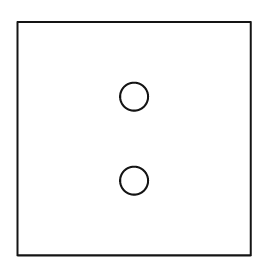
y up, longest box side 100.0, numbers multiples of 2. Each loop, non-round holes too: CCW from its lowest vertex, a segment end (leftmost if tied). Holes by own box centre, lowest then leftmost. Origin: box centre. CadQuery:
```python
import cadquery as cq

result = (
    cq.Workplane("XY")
    .moveTo(-50.0, -50.0)
    .lineTo(50.0, -50.0)
    .lineTo(50.0, 50.0)
    .lineTo(-50.0, 50.0)
    .close()
    .moveTo(0.0, -18.0)
    .circle(6.0)
    .moveTo(0.0, 18.0)
    .circle(6.0)
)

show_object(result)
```